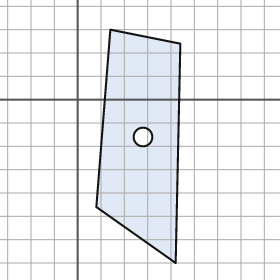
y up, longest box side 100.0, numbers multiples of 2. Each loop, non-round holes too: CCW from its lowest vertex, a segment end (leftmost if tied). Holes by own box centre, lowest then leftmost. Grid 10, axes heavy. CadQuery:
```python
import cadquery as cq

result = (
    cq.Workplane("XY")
    .moveTo(42.0, -70.0)
    .lineTo(44.0, 24.0)
    .lineTo(14.0, 30.0)
    .lineTo(8.0, -46.0)
    .close()
    .moveTo(28.0, -16.0)
    .circle(4.0)
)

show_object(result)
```